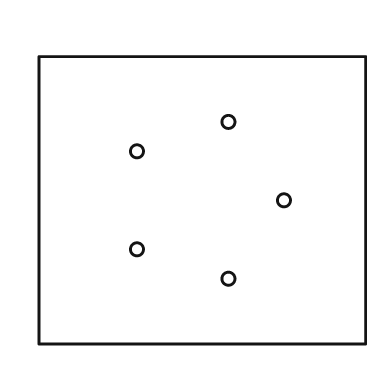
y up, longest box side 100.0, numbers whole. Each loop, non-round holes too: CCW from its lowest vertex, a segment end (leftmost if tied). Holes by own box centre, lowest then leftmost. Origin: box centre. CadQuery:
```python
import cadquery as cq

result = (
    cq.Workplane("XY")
    .moveTo(-50.0, -44.0)
    .lineTo(50.0, -44.0)
    .lineTo(50.0, 44.0)
    .lineTo(-50.0, 44.0)
    .close()
    .moveTo(8.0, -24.0)
    .circle(2.0)
    .moveTo(-20.0, -15.0)
    .circle(2.0)
    .moveTo(25.0, 0.0)
    .circle(2.0)
    .moveTo(-20.0, 15.0)
    .circle(2.0)
    .moveTo(8.0, 24.0)
    .circle(2.0)
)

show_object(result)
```